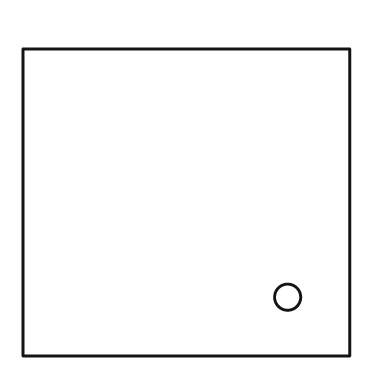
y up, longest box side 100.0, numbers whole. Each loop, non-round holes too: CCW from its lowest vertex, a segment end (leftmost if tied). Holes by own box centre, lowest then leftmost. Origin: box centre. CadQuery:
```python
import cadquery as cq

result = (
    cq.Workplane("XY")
    .moveTo(-50.0, -47.0)
    .lineTo(50.0, -47.0)
    .lineTo(50.0, 47.0)
    .lineTo(-50.0, 47.0)
    .close()
    .moveTo(31.0, -29.0)
    .circle(4.0)
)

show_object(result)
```